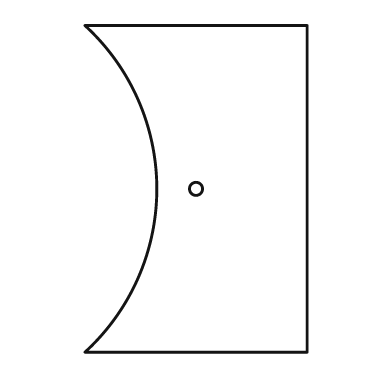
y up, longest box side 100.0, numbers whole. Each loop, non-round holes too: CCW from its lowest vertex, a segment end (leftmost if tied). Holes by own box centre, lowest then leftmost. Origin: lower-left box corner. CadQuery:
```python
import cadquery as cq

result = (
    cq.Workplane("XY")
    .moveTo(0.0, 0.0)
    .lineTo(68.0, 0.0)
    .lineTo(68.0, 100.0)
    .lineTo(0.0, 100.0)
    .threePointArc((22.0, 50.0), (0.0, 0.0))
    .close()
    .moveTo(34.0, 50.0)
    .circle(2.0)
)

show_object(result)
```